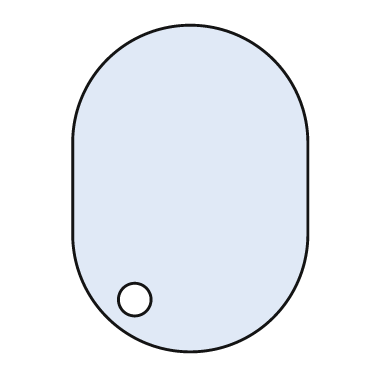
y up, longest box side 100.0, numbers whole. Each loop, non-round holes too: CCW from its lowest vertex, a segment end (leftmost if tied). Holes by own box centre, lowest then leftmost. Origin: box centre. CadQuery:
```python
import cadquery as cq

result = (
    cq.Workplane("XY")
    .moveTo(-36.0, -14.0)
    .threePointArc((0.0, -50.0), (36.0, -14.0))
    .lineTo(36.0, 14.0)
    .threePointArc((0.0, 50.0), (-36.0, 14.0))
    .close()
    .moveTo(-17.0, -34.0)
    .circle(5.0)
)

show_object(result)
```